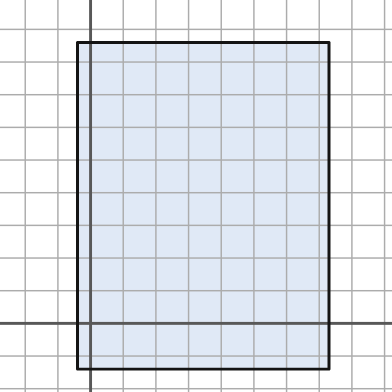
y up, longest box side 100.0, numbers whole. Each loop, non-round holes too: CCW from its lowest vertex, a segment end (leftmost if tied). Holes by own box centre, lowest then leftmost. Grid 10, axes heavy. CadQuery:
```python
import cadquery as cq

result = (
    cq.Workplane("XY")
    .moveTo(-4.0, -14.0)
    .lineTo(73.0, -14.0)
    .lineTo(73.0, 86.0)
    .lineTo(-4.0, 86.0)
    .close()
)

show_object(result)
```